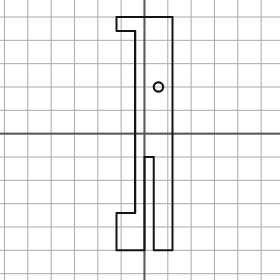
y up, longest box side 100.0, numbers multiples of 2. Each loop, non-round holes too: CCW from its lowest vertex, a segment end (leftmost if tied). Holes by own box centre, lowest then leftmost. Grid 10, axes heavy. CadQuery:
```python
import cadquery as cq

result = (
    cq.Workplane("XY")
    .moveTo(-12.0, -50.0)
    .lineTo(0.0, -50.0)
    .lineTo(0.0, -10.0)
    .lineTo(4.0, -10.0)
    .lineTo(4.0, -50.0)
    .lineTo(12.0, -50.0)
    .lineTo(12.0, 50.0)
    .lineTo(-12.0, 50.0)
    .lineTo(-12.0, 44.0)
    .lineTo(-4.0, 44.0)
    .lineTo(-4.0, -34.0)
    .lineTo(-12.0, -34.0)
    .close()
    .moveTo(6.0, 20.0)
    .circle(2.0)
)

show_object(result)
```